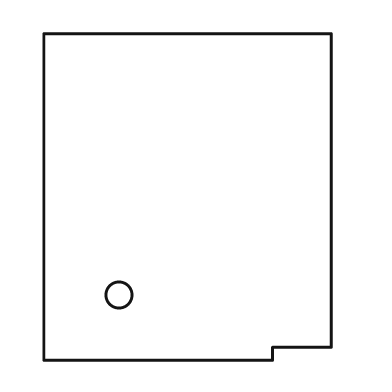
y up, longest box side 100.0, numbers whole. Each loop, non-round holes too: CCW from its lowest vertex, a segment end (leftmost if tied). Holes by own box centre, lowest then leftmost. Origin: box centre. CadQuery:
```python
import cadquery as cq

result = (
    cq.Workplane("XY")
    .moveTo(-44.0, -50.0)
    .lineTo(26.0, -50.0)
    .lineTo(26.0, -46.0)
    .lineTo(44.0, -46.0)
    .lineTo(44.0, 50.0)
    .lineTo(-44.0, 50.0)
    .close()
    .moveTo(-21.0, -30.0)
    .circle(4.0)
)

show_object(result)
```